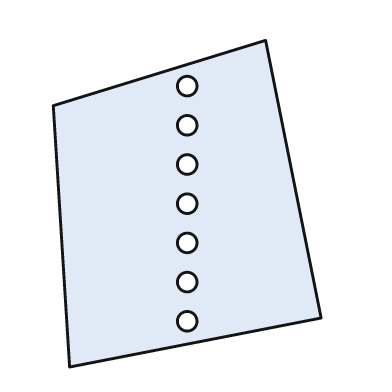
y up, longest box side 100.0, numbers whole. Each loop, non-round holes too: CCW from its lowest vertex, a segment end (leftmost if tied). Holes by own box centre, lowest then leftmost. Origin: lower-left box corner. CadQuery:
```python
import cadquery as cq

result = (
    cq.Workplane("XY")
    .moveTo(5.0, 0.0)
    .lineTo(82.0, 15.0)
    .lineTo(65.0, 100.0)
    .lineTo(0.0, 80.0)
    .close()
    .moveTo(41.0, 14.0)
    .circle(3.0)
    .moveTo(41.0, 26.0)
    .circle(3.0)
    .moveTo(41.0, 38.0)
    .circle(3.0)
    .moveTo(41.0, 50.0)
    .circle(3.0)
    .moveTo(41.0, 62.0)
    .circle(3.0)
    .moveTo(41.0, 74.0)
    .circle(3.0)
    .moveTo(41.0, 86.0)
    .circle(3.0)
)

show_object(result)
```